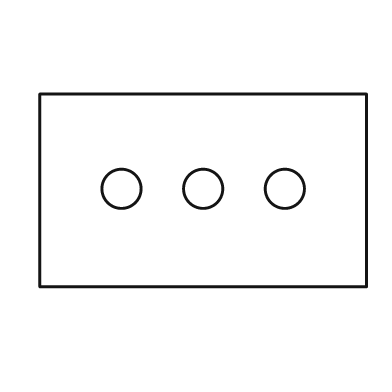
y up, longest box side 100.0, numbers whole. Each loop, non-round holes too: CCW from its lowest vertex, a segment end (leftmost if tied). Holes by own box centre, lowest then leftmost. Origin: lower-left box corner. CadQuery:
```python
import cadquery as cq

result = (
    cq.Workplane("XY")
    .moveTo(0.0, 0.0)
    .lineTo(100.0, 0.0)
    .lineTo(100.0, 59.0)
    .lineTo(0.0, 59.0)
    .close()
    .moveTo(25.0, 30.0)
    .circle(6.0)
    .moveTo(50.0, 30.0)
    .circle(6.0)
    .moveTo(75.0, 30.0)
    .circle(6.0)
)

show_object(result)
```